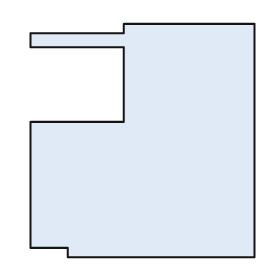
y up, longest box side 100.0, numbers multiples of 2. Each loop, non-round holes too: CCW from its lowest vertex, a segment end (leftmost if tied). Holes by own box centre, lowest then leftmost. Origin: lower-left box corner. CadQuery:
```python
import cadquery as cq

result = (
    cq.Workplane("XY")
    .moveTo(16.0, 0.0)
    .lineTo(96.0, 0.0)
    .lineTo(96.0, 100.0)
    .lineTo(40.0, 100.0)
    .lineTo(40.0, 96.0)
    .lineTo(0.0, 96.0)
    .lineTo(0.0, 90.0)
    .lineTo(40.0, 90.0)
    .lineTo(40.0, 58.0)
    .lineTo(0.0, 58.0)
    .lineTo(0.0, 4.0)
    .lineTo(16.0, 4.0)
    .close()
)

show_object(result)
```